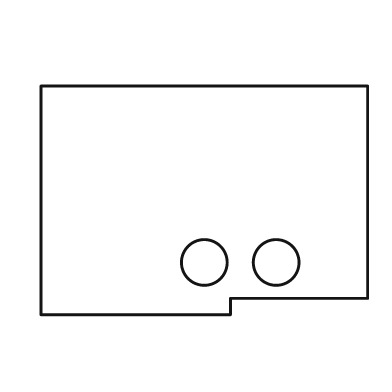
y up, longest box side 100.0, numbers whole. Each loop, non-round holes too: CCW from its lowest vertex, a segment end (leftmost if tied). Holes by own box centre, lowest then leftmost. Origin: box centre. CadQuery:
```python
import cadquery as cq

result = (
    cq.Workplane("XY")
    .moveTo(-50.0, -35.0)
    .lineTo(8.0, -35.0)
    .lineTo(8.0, -30.0)
    .lineTo(50.0, -30.0)
    .lineTo(50.0, 35.0)
    .lineTo(-50.0, 35.0)
    .close()
    .moveTo(0.0, -19.0)
    .circle(7.0)
    .moveTo(22.0, -19.0)
    .circle(7.0)
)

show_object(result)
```